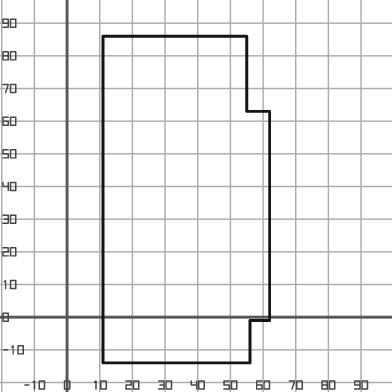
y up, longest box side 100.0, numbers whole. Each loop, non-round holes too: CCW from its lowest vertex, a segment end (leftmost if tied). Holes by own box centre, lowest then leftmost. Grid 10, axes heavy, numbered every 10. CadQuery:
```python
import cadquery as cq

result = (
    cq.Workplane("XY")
    .moveTo(11.0, -14.0)
    .lineTo(56.0, -14.0)
    .lineTo(56.0, -1.0)
    .lineTo(62.0, -1.0)
    .lineTo(62.0, 63.0)
    .lineTo(55.0, 63.0)
    .lineTo(55.0, 86.0)
    .lineTo(11.0, 86.0)
    .close()
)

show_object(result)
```